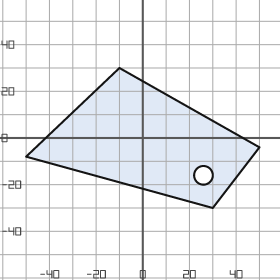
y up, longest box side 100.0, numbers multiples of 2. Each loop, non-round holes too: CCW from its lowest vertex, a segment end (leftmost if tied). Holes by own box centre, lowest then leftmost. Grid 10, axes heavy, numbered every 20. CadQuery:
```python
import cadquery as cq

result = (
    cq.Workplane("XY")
    .moveTo(30.0, -30.0)
    .lineTo(50.0, -4.0)
    .lineTo(-10.0, 30.0)
    .lineTo(-50.0, -8.0)
    .close()
    .moveTo(26.0, -16.0)
    .circle(4.0)
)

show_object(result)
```